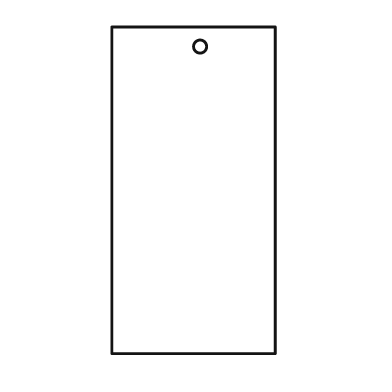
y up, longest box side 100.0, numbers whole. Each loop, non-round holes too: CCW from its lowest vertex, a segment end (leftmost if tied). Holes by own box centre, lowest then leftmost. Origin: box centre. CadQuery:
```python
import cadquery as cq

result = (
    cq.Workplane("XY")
    .moveTo(-25.0, -50.0)
    .lineTo(25.0, -50.0)
    .lineTo(25.0, 50.0)
    .lineTo(-25.0, 50.0)
    .close()
    .moveTo(2.0, 44.0)
    .circle(2.0)
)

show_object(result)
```